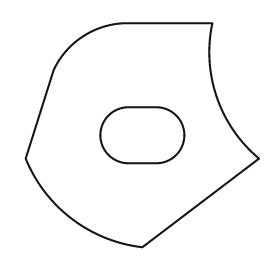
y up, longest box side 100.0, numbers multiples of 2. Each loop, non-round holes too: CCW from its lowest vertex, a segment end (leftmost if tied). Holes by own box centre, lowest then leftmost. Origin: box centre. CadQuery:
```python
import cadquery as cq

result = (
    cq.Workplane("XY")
    .moveTo(0.0, -48.0)
    .lineTo(50.0, -10.0)
    .threePointArc((32.0, 16.0), (30.0, 48.0))
    .lineTo(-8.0, 48.0)
    .threePointArc((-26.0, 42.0), (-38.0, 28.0))
    .lineTo(-50.0, -10.0)
    .threePointArc((-30.0, -36.0), (0.0, -48.0))
    .close()
    .moveTo(-6.0, -12.0)
    .lineTo(6.0, -12.0)
    .threePointArc((18.0, 0.0), (6.0, 12.0))
    .lineTo(-6.0, 12.0)
    .threePointArc((-18.0, 0.0), (-6.0, -12.0))
    .close()
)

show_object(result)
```